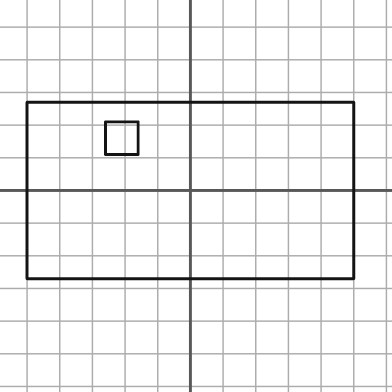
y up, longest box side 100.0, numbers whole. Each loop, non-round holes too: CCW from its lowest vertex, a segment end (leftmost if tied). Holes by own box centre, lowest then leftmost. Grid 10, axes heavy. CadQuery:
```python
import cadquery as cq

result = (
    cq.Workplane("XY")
    .moveTo(-50.0, -27.0)
    .lineTo(50.0, -27.0)
    .lineTo(50.0, 27.0)
    .lineTo(-50.0, 27.0)
    .close()
    .moveTo(-26.0, 11.0)
    .lineTo(-16.0, 11.0)
    .lineTo(-16.0, 21.0)
    .lineTo(-26.0, 21.0)
    .close()
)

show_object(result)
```